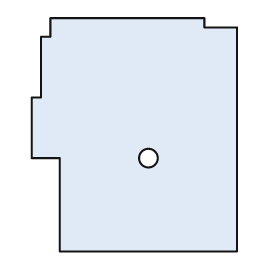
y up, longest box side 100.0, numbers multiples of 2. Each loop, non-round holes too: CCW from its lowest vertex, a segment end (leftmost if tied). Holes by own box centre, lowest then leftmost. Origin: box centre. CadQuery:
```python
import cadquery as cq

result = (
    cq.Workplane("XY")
    .moveTo(-32.0, -50.0)
    .lineTo(44.0, -50.0)
    .lineTo(44.0, 46.0)
    .lineTo(30.0, 46.0)
    .lineTo(30.0, 50.0)
    .lineTo(-36.0, 50.0)
    .lineTo(-36.0, 42.0)
    .lineTo(-40.0, 42.0)
    .lineTo(-40.0, 16.0)
    .lineTo(-44.0, 16.0)
    .lineTo(-44.0, -10.0)
    .lineTo(-32.0, -10.0)
    .close()
    .moveTo(6.0, -10.0)
    .circle(4.0)
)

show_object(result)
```